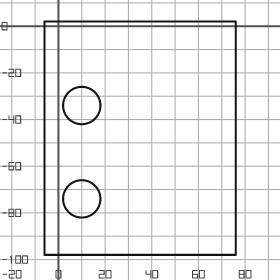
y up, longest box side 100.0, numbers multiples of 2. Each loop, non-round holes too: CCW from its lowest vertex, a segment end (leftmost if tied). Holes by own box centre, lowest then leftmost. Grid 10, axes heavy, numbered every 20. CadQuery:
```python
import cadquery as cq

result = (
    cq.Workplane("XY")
    .moveTo(-6.0, -98.0)
    .lineTo(76.0, -98.0)
    .lineTo(76.0, 2.0)
    .lineTo(-6.0, 2.0)
    .close()
    .moveTo(10.0, -74.0)
    .circle(8.0)
    .moveTo(10.0, -34.0)
    .circle(8.0)
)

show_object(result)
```